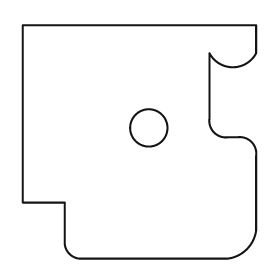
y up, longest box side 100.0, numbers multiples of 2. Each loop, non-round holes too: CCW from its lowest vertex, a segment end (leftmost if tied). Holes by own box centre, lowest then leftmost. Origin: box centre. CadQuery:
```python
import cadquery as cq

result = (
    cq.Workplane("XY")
    .moveTo(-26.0, -50.0)
    .lineTo(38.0, -50.0)
    .threePointArc((46.0, -46.0), (50.0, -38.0))
    .lineTo(50.0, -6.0)
    .threePointArc((48.0, 0.0), (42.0, 2.0))
    .lineTo(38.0, 2.0)
    .threePointArc((32.0, 4.0), (30.0, 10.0))
    .lineTo(30.0, 38.0)
    .threePointArc((40.0, 32.0), (50.0, 38.0))
    .lineTo(50.0, 50.0)
    .lineTo(-50.0, 50.0)
    .lineTo(-50.0, -26.0)
    .lineTo(-32.0, -26.0)
    .lineTo(-32.0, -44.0)
    .threePointArc((-30.0, -48.0), (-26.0, -50.0))
    .close()
    .moveTo(4.0, 6.0)
    .circle(8.0)
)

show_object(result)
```